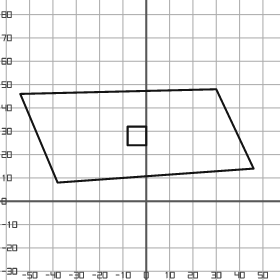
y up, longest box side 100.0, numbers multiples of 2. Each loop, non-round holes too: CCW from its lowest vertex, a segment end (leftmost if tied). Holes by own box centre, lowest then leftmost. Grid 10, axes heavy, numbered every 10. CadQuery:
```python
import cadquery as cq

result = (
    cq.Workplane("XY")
    .moveTo(-38.0, 8.0)
    .lineTo(46.0, 14.0)
    .lineTo(30.0, 48.0)
    .lineTo(-54.0, 46.0)
    .close()
    .moveTo(-8.0, 24.0)
    .lineTo(0.0, 24.0)
    .lineTo(0.0, 32.0)
    .lineTo(-8.0, 32.0)
    .close()
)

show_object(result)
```